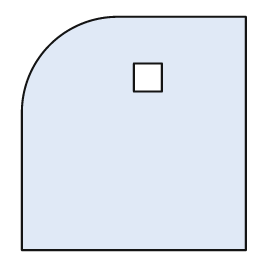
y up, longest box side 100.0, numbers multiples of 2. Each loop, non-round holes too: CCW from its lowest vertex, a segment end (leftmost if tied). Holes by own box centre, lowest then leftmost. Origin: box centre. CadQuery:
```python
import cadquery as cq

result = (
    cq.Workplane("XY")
    .moveTo(-48.0, -50.0)
    .lineTo(48.0, -50.0)
    .lineTo(48.0, 50.0)
    .lineTo(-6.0, 50.0)
    .threePointArc((-36.0, 38.0), (-48.0, 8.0))
    .close()
    .moveTo(0.0, 18.0)
    .lineTo(12.0, 18.0)
    .lineTo(12.0, 30.0)
    .lineTo(0.0, 30.0)
    .close()
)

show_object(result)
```